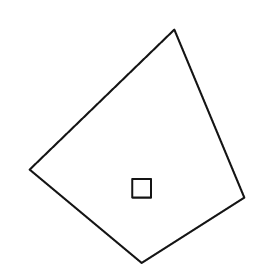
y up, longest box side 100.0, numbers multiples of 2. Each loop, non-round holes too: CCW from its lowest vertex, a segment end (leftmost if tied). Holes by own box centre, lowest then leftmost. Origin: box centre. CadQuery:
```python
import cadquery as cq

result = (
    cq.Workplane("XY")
    .moveTo(2.0, -50.0)
    .lineTo(46.0, -22.0)
    .lineTo(16.0, 50.0)
    .lineTo(-46.0, -10.0)
    .close()
    .moveTo(-2.0, -22.0)
    .lineTo(6.0, -22.0)
    .lineTo(6.0, -14.0)
    .lineTo(-2.0, -14.0)
    .close()
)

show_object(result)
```